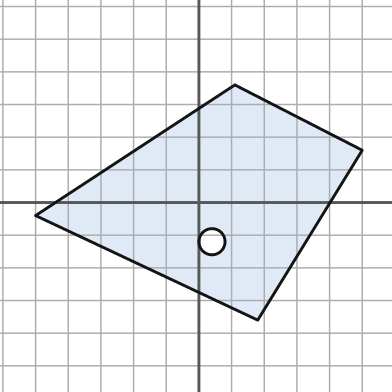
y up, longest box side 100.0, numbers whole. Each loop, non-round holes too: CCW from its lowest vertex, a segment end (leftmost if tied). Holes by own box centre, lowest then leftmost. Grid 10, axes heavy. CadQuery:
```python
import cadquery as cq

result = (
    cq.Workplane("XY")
    .moveTo(18.0, -36.0)
    .lineTo(50.0, 16.0)
    .lineTo(11.0, 36.0)
    .lineTo(-50.0, -4.0)
    .close()
    .moveTo(4.0, -12.0)
    .circle(4.0)
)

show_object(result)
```